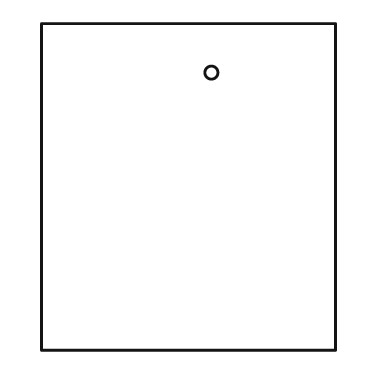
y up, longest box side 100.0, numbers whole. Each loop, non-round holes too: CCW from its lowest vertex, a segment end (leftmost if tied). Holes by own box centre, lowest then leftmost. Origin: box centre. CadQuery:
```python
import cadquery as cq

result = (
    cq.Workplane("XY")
    .moveTo(-45.0, -50.0)
    .lineTo(45.0, -50.0)
    .lineTo(45.0, 50.0)
    .lineTo(-45.0, 50.0)
    .close()
    .moveTo(7.0, 35.0)
    .circle(2.0)
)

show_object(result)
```